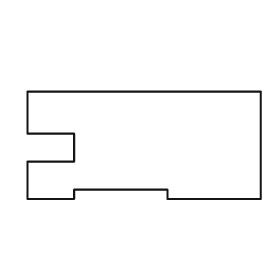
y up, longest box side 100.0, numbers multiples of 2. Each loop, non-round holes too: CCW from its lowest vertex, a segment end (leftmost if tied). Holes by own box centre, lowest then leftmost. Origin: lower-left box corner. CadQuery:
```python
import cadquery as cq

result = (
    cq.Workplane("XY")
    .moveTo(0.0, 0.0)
    .lineTo(20.0, 0.0)
    .lineTo(20.0, 4.0)
    .lineTo(60.0, 4.0)
    .lineTo(60.0, 0.0)
    .lineTo(100.0, 0.0)
    .lineTo(100.0, 46.0)
    .lineTo(0.0, 46.0)
    .lineTo(0.0, 28.0)
    .lineTo(20.0, 28.0)
    .lineTo(20.0, 16.0)
    .lineTo(0.0, 16.0)
    .close()
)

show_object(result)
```